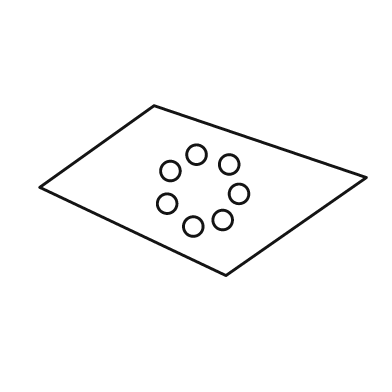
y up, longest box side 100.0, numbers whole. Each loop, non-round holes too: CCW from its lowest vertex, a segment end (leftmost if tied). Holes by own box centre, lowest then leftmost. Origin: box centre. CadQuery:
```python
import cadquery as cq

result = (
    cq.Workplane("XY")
    .moveTo(7.0, -26.0)
    .lineTo(50.0, 4.0)
    .lineTo(-15.0, 26.0)
    .lineTo(-50.0, 1.0)
    .close()
    .moveTo(-3.0, -11.0)
    .circle(3.0)
    .moveTo(6.0, -9.0)
    .circle(3.0)
    .moveTo(-11.0, -4.0)
    .circle(3.0)
    .moveTo(11.0, -1.0)
    .circle(3.0)
    .moveTo(-10.0, 6.0)
    .circle(3.0)
    .moveTo(8.0, 8.0)
    .circle(3.0)
    .moveTo(-2.0, 11.0)
    .circle(3.0)
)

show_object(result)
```